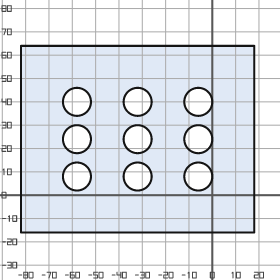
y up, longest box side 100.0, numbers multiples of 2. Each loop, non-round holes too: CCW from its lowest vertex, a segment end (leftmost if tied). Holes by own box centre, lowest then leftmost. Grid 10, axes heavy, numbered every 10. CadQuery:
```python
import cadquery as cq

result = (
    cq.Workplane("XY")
    .moveTo(-82.0, -16.0)
    .lineTo(18.0, -16.0)
    .lineTo(18.0, 64.0)
    .lineTo(-82.0, 64.0)
    .close()
    .moveTo(-58.0, 8.0)
    .circle(6.0)
    .moveTo(-32.0, 8.0)
    .circle(6.0)
    .moveTo(-6.0, 8.0)
    .circle(6.0)
    .moveTo(-58.0, 24.0)
    .circle(6.0)
    .moveTo(-32.0, 24.0)
    .circle(6.0)
    .moveTo(-6.0, 24.0)
    .circle(6.0)
    .moveTo(-58.0, 40.0)
    .circle(6.0)
    .moveTo(-32.0, 40.0)
    .circle(6.0)
    .moveTo(-6.0, 40.0)
    .circle(6.0)
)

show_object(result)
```